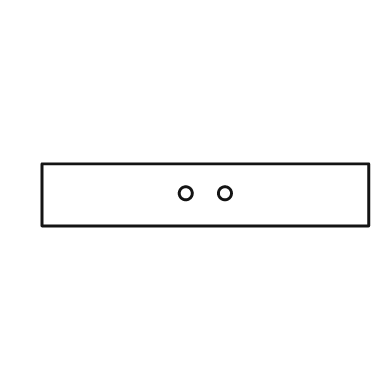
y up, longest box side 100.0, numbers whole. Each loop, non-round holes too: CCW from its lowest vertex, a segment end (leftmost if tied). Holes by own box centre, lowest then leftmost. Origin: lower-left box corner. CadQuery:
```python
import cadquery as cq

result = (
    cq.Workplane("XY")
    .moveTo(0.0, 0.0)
    .lineTo(100.0, 0.0)
    .lineTo(100.0, 19.0)
    .lineTo(0.0, 19.0)
    .close()
    .moveTo(44.0, 10.0)
    .circle(2.0)
    .moveTo(56.0, 10.0)
    .circle(2.0)
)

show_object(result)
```